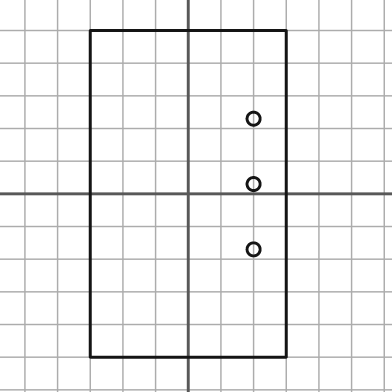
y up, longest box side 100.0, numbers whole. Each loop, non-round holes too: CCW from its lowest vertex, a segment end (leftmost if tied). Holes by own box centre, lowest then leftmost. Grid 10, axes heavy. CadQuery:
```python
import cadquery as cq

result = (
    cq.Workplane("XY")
    .moveTo(-30.0, -50.0)
    .lineTo(30.0, -50.0)
    .lineTo(30.0, 50.0)
    .lineTo(-30.0, 50.0)
    .close()
    .moveTo(20.0, -17.0)
    .circle(2.0)
    .moveTo(20.0, 3.0)
    .circle(2.0)
    .moveTo(20.0, 23.0)
    .circle(2.0)
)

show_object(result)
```